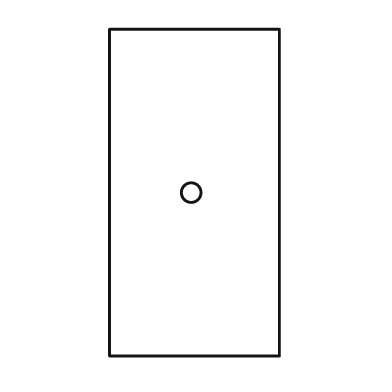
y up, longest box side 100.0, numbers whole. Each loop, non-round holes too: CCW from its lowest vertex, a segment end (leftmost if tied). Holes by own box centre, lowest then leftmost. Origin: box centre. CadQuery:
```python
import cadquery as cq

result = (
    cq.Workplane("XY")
    .moveTo(-26.0, -50.0)
    .lineTo(26.0, -50.0)
    .lineTo(26.0, 50.0)
    .lineTo(-26.0, 50.0)
    .close()
    .moveTo(-1.0, 0.0)
    .circle(3.0)
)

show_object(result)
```